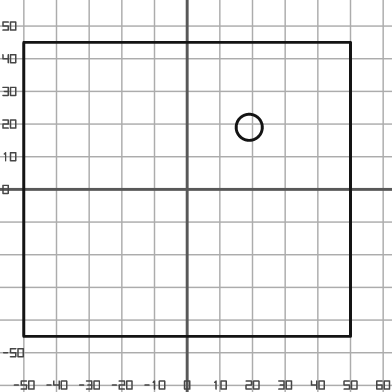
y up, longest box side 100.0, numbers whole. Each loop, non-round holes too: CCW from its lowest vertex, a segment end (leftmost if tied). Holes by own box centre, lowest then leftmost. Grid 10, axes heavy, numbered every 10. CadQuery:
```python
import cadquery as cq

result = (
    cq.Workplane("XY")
    .moveTo(-50.0, -45.0)
    .lineTo(50.0, -45.0)
    .lineTo(50.0, 45.0)
    .lineTo(-50.0, 45.0)
    .close()
    .moveTo(19.0, 19.0)
    .circle(4.0)
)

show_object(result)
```